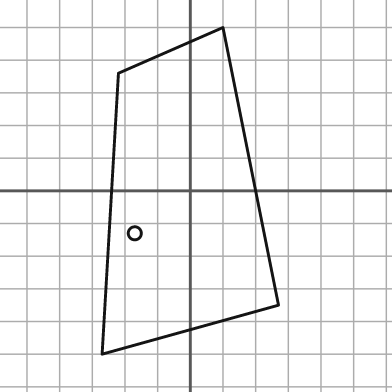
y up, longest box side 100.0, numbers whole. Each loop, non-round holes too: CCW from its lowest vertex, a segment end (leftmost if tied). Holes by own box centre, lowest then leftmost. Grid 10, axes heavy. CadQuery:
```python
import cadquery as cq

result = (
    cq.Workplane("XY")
    .moveTo(-27.0, -50.0)
    .lineTo(27.0, -35.0)
    .lineTo(10.0, 50.0)
    .lineTo(-22.0, 36.0)
    .close()
    .moveTo(-17.0, -13.0)
    .circle(2.0)
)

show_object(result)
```